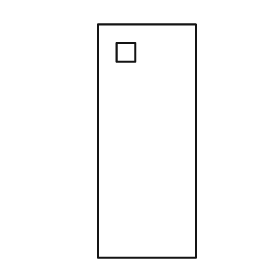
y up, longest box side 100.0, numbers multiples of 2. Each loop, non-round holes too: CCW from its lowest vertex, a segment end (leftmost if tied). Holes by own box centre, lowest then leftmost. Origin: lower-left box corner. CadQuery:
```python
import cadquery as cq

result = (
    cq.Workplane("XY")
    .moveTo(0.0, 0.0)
    .lineTo(42.0, 0.0)
    .lineTo(42.0, 100.0)
    .lineTo(0.0, 100.0)
    .close()
    .moveTo(8.0, 84.0)
    .lineTo(16.0, 84.0)
    .lineTo(16.0, 92.0)
    .lineTo(8.0, 92.0)
    .close()
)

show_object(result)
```